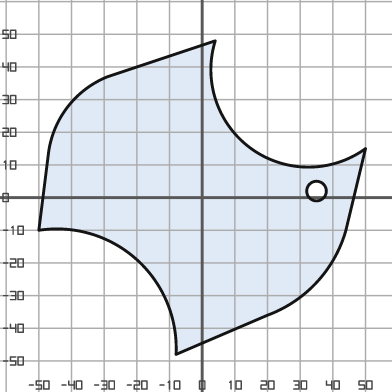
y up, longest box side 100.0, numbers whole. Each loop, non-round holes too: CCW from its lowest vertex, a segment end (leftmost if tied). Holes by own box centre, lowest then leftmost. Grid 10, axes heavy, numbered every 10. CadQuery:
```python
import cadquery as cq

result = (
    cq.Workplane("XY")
    .moveTo(-8.0, -48.0)
    .lineTo(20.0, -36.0)
    .threePointArc((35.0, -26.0), (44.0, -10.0))
    .lineTo(50.0, 15.0)
    .threePointArc((15.0, 15.0), (4.0, 48.0))
    .lineTo(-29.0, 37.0)
    .threePointArc((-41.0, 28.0), (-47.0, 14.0))
    .lineTo(-50.0, -10.0)
    .threePointArc((-20.0, -19.0), (-8.0, -48.0))
    .close()
    .moveTo(35.0, 2.0)
    .circle(3.0)
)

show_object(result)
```